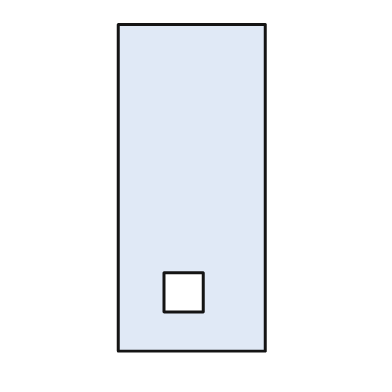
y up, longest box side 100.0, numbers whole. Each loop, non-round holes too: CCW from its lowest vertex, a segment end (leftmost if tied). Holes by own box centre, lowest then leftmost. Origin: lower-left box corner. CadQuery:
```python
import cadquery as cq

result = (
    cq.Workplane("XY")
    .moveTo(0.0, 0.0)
    .lineTo(45.0, 0.0)
    .lineTo(45.0, 100.0)
    .lineTo(0.0, 100.0)
    .close()
    .moveTo(14.0, 12.0)
    .lineTo(26.0, 12.0)
    .lineTo(26.0, 24.0)
    .lineTo(14.0, 24.0)
    .close()
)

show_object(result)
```